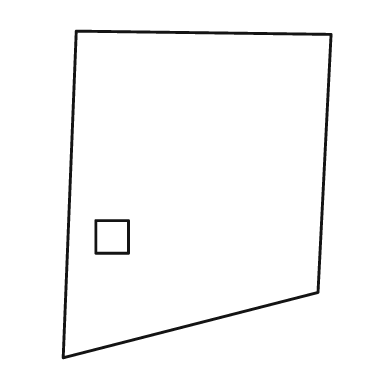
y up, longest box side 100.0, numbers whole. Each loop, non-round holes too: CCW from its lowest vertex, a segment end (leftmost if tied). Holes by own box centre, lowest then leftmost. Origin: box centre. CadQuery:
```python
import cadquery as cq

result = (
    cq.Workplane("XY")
    .moveTo(-41.0, -50.0)
    .lineTo(37.0, -30.0)
    .lineTo(41.0, 49.0)
    .lineTo(-37.0, 50.0)
    .close()
    .moveTo(-31.0, -18.0)
    .lineTo(-21.0, -18.0)
    .lineTo(-21.0, -8.0)
    .lineTo(-31.0, -8.0)
    .close()
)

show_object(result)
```